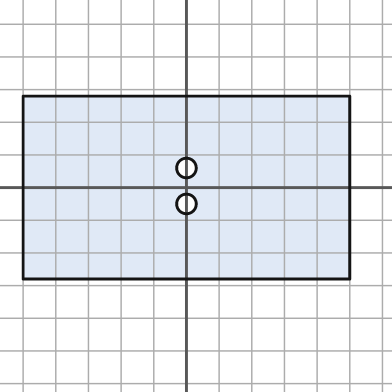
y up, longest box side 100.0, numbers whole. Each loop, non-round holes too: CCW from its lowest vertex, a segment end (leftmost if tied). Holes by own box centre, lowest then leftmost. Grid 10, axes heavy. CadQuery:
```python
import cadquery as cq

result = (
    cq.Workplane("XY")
    .moveTo(-50.0, -28.0)
    .lineTo(50.0, -28.0)
    .lineTo(50.0, 28.0)
    .lineTo(-50.0, 28.0)
    .close()
    .moveTo(0.0, -5.0)
    .circle(3.0)
    .moveTo(0.0, 6.0)
    .circle(3.0)
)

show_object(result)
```